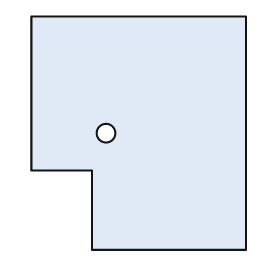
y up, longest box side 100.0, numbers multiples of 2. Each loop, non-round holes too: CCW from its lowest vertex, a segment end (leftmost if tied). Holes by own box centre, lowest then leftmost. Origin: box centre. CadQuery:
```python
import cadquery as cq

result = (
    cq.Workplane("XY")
    .moveTo(-20.0, -50.0)
    .lineTo(46.0, -50.0)
    .lineTo(46.0, 50.0)
    .lineTo(-46.0, 50.0)
    .lineTo(-46.0, -16.0)
    .lineTo(-20.0, -16.0)
    .close()
    .moveTo(-14.0, 0.0)
    .circle(4.0)
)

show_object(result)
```